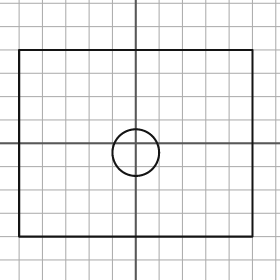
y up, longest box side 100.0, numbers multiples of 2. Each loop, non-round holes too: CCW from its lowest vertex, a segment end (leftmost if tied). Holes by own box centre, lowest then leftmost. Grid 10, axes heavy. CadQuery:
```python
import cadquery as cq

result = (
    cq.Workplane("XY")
    .moveTo(-50.0, -40.0)
    .lineTo(50.0, -40.0)
    .lineTo(50.0, 40.0)
    .lineTo(-50.0, 40.0)
    .close()
    .moveTo(0.0, -4.0)
    .circle(10.0)
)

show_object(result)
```